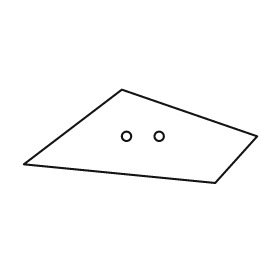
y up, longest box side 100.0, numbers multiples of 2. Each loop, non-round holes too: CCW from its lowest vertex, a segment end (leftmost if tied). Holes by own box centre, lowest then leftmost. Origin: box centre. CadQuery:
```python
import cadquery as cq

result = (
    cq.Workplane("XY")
    .moveTo(32.0, -20.0)
    .lineTo(50.0, 0.0)
    .lineTo(-8.0, 20.0)
    .lineTo(-50.0, -12.0)
    .close()
    .moveTo(-6.0, 0.0)
    .circle(2.0)
    .moveTo(8.0, 0.0)
    .circle(2.0)
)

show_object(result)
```